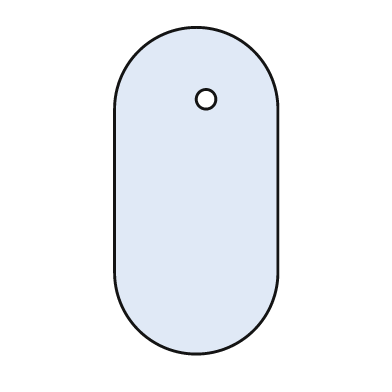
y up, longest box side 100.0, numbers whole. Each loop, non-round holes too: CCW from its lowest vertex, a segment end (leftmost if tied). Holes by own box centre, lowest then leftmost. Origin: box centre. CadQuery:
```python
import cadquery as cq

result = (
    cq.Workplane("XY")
    .moveTo(-25.0, -25.0)
    .threePointArc((0.0, -50.0), (25.0, -25.0))
    .lineTo(25.0, 25.0)
    .threePointArc((0.0, 50.0), (-25.0, 25.0))
    .close()
    .moveTo(3.0, 28.0)
    .circle(3.0)
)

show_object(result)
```